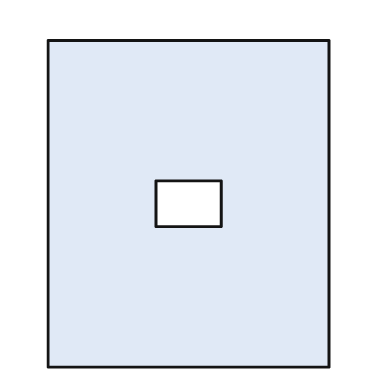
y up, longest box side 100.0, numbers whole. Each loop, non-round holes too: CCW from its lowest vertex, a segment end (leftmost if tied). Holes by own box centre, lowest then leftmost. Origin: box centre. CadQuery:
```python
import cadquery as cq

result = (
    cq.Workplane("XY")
    .moveTo(-43.0, -50.0)
    .lineTo(43.0, -50.0)
    .lineTo(43.0, 50.0)
    .lineTo(-43.0, 50.0)
    .close()
    .moveTo(-10.0, -7.0)
    .lineTo(10.0, -7.0)
    .lineTo(10.0, 7.0)
    .lineTo(-10.0, 7.0)
    .close()
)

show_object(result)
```